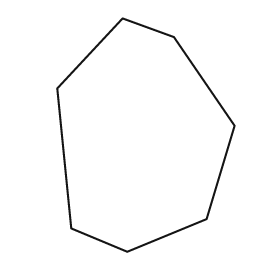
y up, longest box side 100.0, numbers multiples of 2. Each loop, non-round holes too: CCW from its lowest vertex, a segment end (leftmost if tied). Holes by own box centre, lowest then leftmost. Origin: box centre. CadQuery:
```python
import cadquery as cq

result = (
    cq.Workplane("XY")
    .moveTo(-8.0, -50.0)
    .lineTo(26.0, -36.0)
    .lineTo(38.0, 4.0)
    .lineTo(12.0, 42.0)
    .lineTo(-10.0, 50.0)
    .lineTo(-38.0, 20.0)
    .lineTo(-32.0, -40.0)
    .close()
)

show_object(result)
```